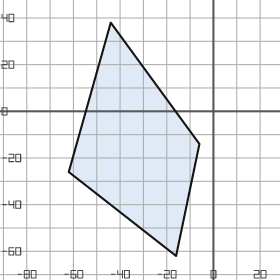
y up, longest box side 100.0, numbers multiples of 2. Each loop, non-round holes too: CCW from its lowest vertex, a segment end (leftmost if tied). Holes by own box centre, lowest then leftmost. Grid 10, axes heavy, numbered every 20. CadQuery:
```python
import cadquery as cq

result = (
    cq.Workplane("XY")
    .moveTo(-16.0, -62.0)
    .lineTo(-6.0, -14.0)
    .lineTo(-44.0, 38.0)
    .lineTo(-62.0, -26.0)
    .close()
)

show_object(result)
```